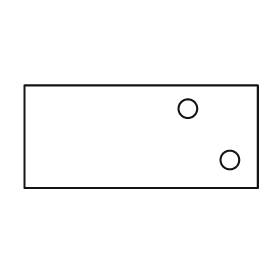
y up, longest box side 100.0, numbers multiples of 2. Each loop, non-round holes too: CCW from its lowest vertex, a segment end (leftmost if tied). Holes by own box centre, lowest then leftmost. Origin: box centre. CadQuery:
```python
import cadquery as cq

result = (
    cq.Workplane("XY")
    .moveTo(-50.0, -22.0)
    .lineTo(50.0, -22.0)
    .lineTo(50.0, 22.0)
    .lineTo(-50.0, 22.0)
    .close()
    .moveTo(38.0, -10.0)
    .circle(4.0)
    .moveTo(20.0, 12.0)
    .circle(4.0)
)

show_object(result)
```